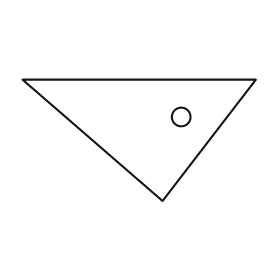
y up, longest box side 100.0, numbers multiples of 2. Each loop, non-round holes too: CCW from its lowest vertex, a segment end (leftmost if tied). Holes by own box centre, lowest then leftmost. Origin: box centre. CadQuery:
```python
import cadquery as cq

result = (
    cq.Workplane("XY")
    .moveTo(10.0, -26.0)
    .lineTo(50.0, 26.0)
    .lineTo(-50.0, 26.0)
    .close()
    .moveTo(18.0, 10.0)
    .circle(4.0)
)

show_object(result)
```